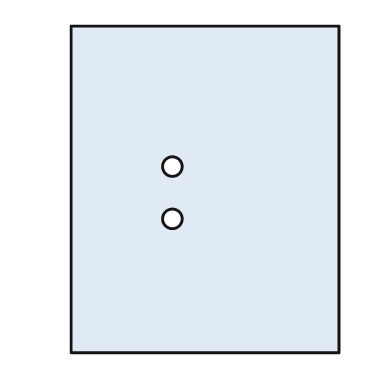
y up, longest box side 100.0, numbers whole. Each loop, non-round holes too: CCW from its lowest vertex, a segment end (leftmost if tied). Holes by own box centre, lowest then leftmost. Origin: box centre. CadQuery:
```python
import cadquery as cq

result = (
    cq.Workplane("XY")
    .moveTo(-41.0, -50.0)
    .lineTo(41.0, -50.0)
    .lineTo(41.0, 50.0)
    .lineTo(-41.0, 50.0)
    .close()
    .moveTo(-10.0, -9.0)
    .circle(3.0)
    .moveTo(-10.0, 7.0)
    .circle(3.0)
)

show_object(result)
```